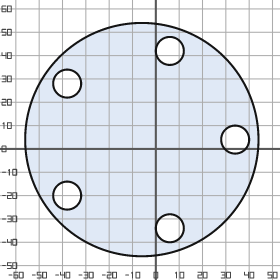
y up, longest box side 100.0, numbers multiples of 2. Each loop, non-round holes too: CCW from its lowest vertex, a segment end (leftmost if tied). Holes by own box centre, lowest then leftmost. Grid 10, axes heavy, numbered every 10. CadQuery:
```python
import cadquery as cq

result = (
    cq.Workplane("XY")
    .moveTo(-6.0, 4.0)
    .circle(50.0)
    .moveTo(6.0, -34.0)
    .circle(6.0)
    .moveTo(-38.0, -20.0)
    .circle(6.0)
    .moveTo(34.0, 4.0)
    .circle(6.0)
    .moveTo(-38.0, 28.0)
    .circle(6.0)
    .moveTo(6.0, 42.0)
    .circle(6.0)
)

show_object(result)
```